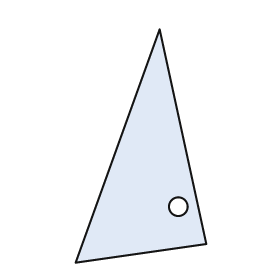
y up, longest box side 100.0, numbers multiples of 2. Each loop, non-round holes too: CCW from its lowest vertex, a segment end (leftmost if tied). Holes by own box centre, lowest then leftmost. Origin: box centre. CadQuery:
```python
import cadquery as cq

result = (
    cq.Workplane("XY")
    .moveTo(-28.0, -50.0)
    .lineTo(28.0, -42.0)
    .lineTo(8.0, 50.0)
    .close()
    .moveTo(16.0, -26.0)
    .circle(4.0)
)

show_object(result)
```